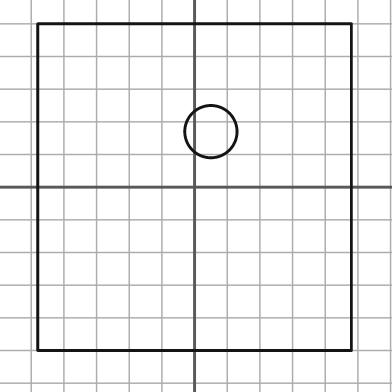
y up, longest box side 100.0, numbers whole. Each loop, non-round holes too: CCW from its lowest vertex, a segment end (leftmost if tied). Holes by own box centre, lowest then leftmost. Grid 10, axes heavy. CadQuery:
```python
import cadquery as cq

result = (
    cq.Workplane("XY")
    .moveTo(-48.0, -50.0)
    .lineTo(48.0, -50.0)
    .lineTo(48.0, 50.0)
    .lineTo(-48.0, 50.0)
    .close()
    .moveTo(5.0, 17.0)
    .circle(8.0)
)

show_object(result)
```